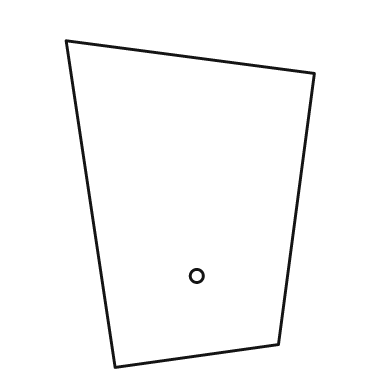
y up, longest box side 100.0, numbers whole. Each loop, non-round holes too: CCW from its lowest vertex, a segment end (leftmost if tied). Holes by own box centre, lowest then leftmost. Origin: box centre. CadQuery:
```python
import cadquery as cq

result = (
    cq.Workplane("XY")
    .moveTo(-23.0, -50.0)
    .lineTo(27.0, -43.0)
    .lineTo(38.0, 40.0)
    .lineTo(-38.0, 50.0)
    .close()
    .moveTo(2.0, -22.0)
    .circle(2.0)
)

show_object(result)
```